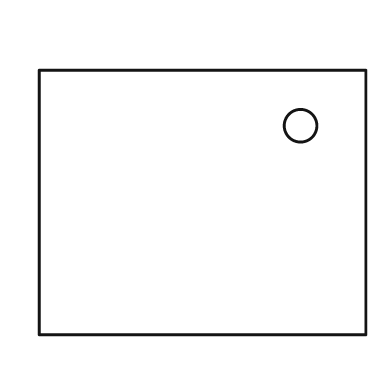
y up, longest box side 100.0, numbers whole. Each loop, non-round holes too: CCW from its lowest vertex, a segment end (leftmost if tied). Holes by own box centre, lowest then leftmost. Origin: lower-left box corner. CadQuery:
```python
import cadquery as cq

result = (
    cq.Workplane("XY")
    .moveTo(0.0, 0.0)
    .lineTo(100.0, 0.0)
    .lineTo(100.0, 81.0)
    .lineTo(0.0, 81.0)
    .close()
    .moveTo(80.0, 64.0)
    .circle(5.0)
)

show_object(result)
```